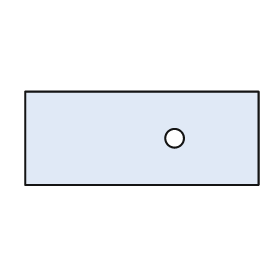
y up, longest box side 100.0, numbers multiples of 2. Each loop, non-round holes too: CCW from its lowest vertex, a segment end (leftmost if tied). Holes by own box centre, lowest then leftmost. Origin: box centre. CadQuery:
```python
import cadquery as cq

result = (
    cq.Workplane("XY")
    .moveTo(-50.0, -20.0)
    .lineTo(50.0, -20.0)
    .lineTo(50.0, 20.0)
    .lineTo(-50.0, 20.0)
    .close()
    .moveTo(14.0, 0.0)
    .circle(4.0)
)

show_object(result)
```